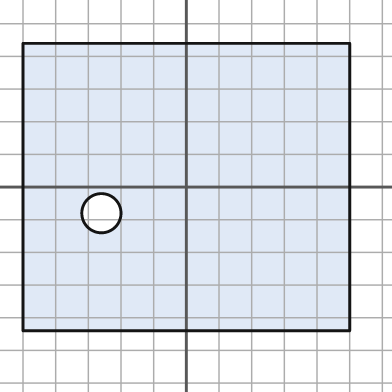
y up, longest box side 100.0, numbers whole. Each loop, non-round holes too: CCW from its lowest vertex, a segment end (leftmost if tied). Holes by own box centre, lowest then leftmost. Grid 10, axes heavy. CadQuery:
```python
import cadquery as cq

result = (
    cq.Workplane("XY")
    .moveTo(-50.0, -44.0)
    .lineTo(50.0, -44.0)
    .lineTo(50.0, 44.0)
    .lineTo(-50.0, 44.0)
    .close()
    .moveTo(-26.0, -8.0)
    .circle(6.0)
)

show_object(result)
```